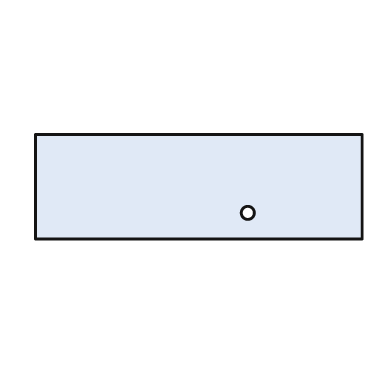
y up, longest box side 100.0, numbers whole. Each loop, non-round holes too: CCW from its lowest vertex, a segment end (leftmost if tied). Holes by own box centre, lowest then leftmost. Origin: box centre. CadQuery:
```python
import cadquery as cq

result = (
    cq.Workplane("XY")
    .moveTo(-50.0, -16.0)
    .lineTo(50.0, -16.0)
    .lineTo(50.0, 16.0)
    .lineTo(-50.0, 16.0)
    .close()
    .moveTo(15.0, -8.0)
    .circle(2.0)
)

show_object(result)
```